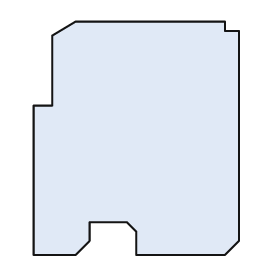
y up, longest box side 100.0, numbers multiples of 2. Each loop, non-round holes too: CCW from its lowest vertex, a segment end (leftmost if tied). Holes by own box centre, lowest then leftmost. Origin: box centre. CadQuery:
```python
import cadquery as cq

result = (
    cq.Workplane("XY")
    .moveTo(-44.0, -50.0)
    .lineTo(-26.0, -50.0)
    .lineTo(-20.0, -44.0)
    .lineTo(-20.0, -36.0)
    .lineTo(-4.0, -36.0)
    .lineTo(0.0, -40.0)
    .lineTo(0.0, -50.0)
    .lineTo(38.0, -50.0)
    .lineTo(44.0, -44.0)
    .lineTo(44.0, 46.0)
    .lineTo(38.0, 46.0)
    .lineTo(38.0, 50.0)
    .lineTo(-26.0, 50.0)
    .lineTo(-36.0, 44.0)
    .lineTo(-36.0, 14.0)
    .lineTo(-44.0, 14.0)
    .close()
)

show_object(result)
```